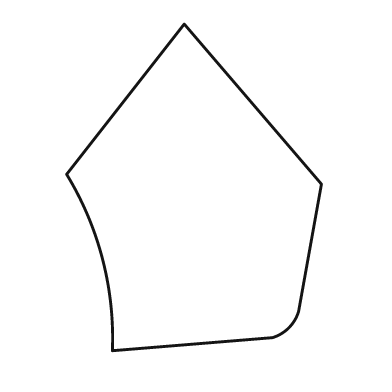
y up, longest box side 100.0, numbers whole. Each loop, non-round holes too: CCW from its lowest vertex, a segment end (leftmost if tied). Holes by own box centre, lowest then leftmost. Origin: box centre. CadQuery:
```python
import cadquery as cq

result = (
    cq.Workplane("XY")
    .moveTo(-25.0, -50.0)
    .lineTo(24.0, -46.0)
    .threePointArc((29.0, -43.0), (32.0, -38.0))
    .lineTo(39.0, 1.0)
    .lineTo(-3.0, 50.0)
    .lineTo(-39.0, 4.0)
    .threePointArc((-28.0, -22.0), (-25.0, -50.0))
    .close()
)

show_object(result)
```